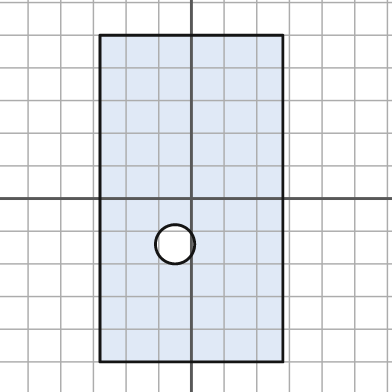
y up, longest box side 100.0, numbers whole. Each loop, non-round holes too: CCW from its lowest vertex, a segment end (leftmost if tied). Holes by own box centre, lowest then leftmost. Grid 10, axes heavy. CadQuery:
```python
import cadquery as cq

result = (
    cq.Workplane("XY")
    .moveTo(-28.0, -50.0)
    .lineTo(28.0, -50.0)
    .lineTo(28.0, 50.0)
    .lineTo(-28.0, 50.0)
    .close()
    .moveTo(-5.0, -14.0)
    .circle(6.0)
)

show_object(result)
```